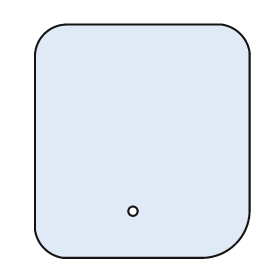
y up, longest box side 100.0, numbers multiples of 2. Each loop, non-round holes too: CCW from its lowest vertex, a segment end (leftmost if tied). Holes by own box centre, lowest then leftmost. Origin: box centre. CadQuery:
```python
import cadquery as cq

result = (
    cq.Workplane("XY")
    .moveTo(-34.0, -50.0)
    .lineTo(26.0, -50.0)
    .threePointArc((40.0, -44.0), (46.0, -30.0))
    .lineTo(46.0, 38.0)
    .threePointArc((42.0, 46.0), (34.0, 50.0))
    .lineTo(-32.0, 50.0)
    .threePointArc((-42.0, 46.0), (-46.0, 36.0))
    .lineTo(-46.0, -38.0)
    .threePointArc((-42.0, -46.0), (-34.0, -50.0))
    .close()
    .moveTo(-4.0, -30.0)
    .circle(2.0)
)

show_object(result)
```